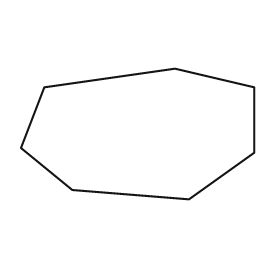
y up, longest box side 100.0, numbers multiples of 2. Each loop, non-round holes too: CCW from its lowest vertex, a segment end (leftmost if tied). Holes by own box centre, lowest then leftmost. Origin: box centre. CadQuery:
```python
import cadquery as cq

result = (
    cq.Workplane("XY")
    .moveTo(22.0, -28.0)
    .lineTo(50.0, -8.0)
    .lineTo(50.0, 20.0)
    .lineTo(16.0, 28.0)
    .lineTo(-40.0, 20.0)
    .lineTo(-50.0, -6.0)
    .lineTo(-28.0, -24.0)
    .close()
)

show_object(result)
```